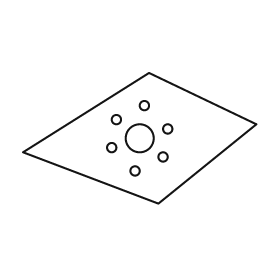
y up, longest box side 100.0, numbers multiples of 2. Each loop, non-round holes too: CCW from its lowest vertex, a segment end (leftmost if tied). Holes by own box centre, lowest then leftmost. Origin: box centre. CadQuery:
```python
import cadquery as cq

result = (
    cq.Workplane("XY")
    .moveTo(8.0, -28.0)
    .lineTo(50.0, 6.0)
    .lineTo(4.0, 28.0)
    .lineTo(-50.0, -6.0)
    .close()
    .moveTo(-2.0, -14.0)
    .circle(2.0)
    .moveTo(10.0, -8.0)
    .circle(2.0)
    .moveTo(-12.0, -4.0)
    .circle(2.0)
    .moveTo(0.0, 0.0)
    .circle(6.0)
    .moveTo(12.0, 4.0)
    .circle(2.0)
    .moveTo(-10.0, 8.0)
    .circle(2.0)
    .moveTo(2.0, 14.0)
    .circle(2.0)
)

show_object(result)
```